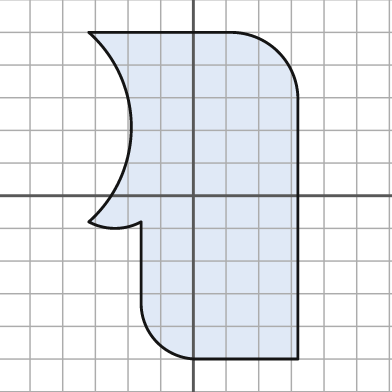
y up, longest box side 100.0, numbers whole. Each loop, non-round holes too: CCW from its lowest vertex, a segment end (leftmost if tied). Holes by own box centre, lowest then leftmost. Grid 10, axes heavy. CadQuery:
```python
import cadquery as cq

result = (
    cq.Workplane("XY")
    .moveTo(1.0, -50.0)
    .lineTo(32.0, -50.0)
    .lineTo(32.0, 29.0)
    .threePointArc((26.0, 44.0), (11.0, 50.0))
    .lineTo(-32.0, 50.0)
    .threePointArc((-19.0, 21.0), (-32.0, -8.0))
    .threePointArc((-24.0, -10.0), (-16.0, -8.0))
    .lineTo(-16.0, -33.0)
    .threePointArc((-11.0, -45.0), (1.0, -50.0))
    .close()
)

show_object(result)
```